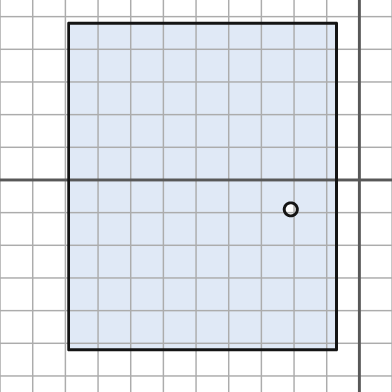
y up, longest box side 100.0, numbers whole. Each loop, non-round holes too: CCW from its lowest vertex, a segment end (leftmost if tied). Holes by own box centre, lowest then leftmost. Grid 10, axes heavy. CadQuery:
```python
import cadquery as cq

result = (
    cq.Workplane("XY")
    .moveTo(-89.0, -52.0)
    .lineTo(-7.0, -52.0)
    .lineTo(-7.0, 48.0)
    .lineTo(-89.0, 48.0)
    .close()
    .moveTo(-21.0, -9.0)
    .circle(2.0)
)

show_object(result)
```